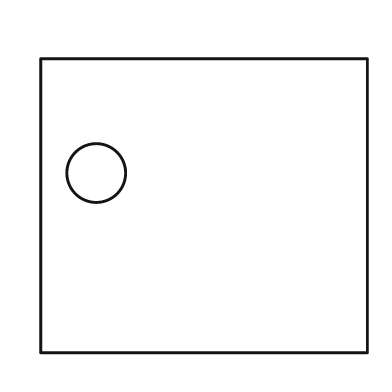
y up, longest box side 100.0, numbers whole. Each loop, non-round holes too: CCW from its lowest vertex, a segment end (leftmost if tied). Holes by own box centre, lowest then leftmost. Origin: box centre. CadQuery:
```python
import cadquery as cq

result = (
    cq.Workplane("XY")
    .moveTo(-50.0, -45.0)
    .lineTo(50.0, -45.0)
    .lineTo(50.0, 45.0)
    .lineTo(-50.0, 45.0)
    .close()
    .moveTo(-33.0, 10.0)
    .circle(9.0)
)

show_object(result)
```